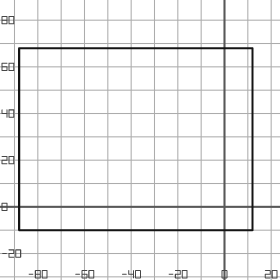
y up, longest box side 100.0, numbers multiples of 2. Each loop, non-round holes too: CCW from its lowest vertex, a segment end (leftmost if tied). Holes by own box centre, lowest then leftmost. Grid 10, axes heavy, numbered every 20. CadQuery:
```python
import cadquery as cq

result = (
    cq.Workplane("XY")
    .moveTo(-88.0, -10.0)
    .lineTo(12.0, -10.0)
    .lineTo(12.0, 68.0)
    .lineTo(-88.0, 68.0)
    .close()
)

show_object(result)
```